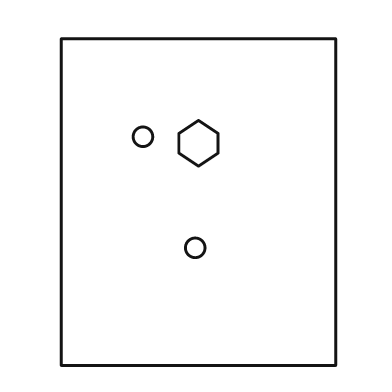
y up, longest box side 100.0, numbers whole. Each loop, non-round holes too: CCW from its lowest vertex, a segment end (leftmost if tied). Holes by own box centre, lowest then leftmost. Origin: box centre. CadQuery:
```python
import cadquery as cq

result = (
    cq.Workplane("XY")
    .moveTo(-42.0, -50.0)
    .lineTo(42.0, -50.0)
    .lineTo(42.0, 50.0)
    .lineTo(-42.0, 50.0)
    .close()
    .moveTo(-1.0, -14.0)
    .circle(3.0)
    .moveTo(0.0, 11.0)
    .lineTo(6.0, 15.0)
    .lineTo(6.0, 21.0)
    .lineTo(0.0, 25.0)
    .lineTo(-6.0, 21.0)
    .lineTo(-6.0, 15.0)
    .close()
    .moveTo(-17.0, 20.0)
    .circle(3.0)
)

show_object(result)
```